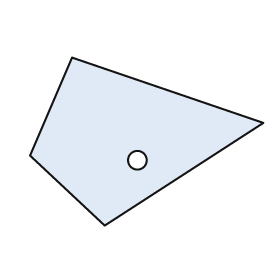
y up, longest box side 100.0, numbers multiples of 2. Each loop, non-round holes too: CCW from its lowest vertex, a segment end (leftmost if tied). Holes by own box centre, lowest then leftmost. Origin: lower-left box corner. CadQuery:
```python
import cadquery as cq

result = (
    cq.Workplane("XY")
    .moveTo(32.0, 0.0)
    .lineTo(100.0, 44.0)
    .lineTo(18.0, 72.0)
    .lineTo(0.0, 30.0)
    .close()
    .moveTo(46.0, 28.0)
    .circle(4.0)
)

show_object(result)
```